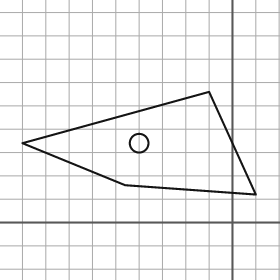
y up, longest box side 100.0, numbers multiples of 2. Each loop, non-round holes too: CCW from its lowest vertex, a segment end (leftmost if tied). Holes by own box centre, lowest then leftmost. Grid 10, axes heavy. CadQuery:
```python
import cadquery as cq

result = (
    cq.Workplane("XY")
    .moveTo(10.0, 12.0)
    .lineTo(-10.0, 56.0)
    .lineTo(-90.0, 34.0)
    .lineTo(-46.0, 16.0)
    .close()
    .moveTo(-40.0, 34.0)
    .circle(4.0)
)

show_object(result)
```